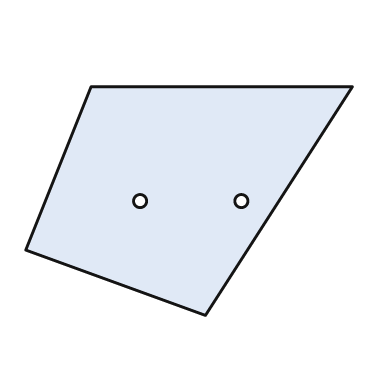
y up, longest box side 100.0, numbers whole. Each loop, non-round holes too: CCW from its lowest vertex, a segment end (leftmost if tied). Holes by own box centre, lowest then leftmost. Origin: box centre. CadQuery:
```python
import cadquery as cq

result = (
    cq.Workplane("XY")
    .moveTo(5.0, -35.0)
    .lineTo(50.0, 35.0)
    .lineTo(-30.0, 35.0)
    .lineTo(-50.0, -15.0)
    .close()
    .moveTo(-15.0, 0.0)
    .circle(2.0)
    .moveTo(16.0, 0.0)
    .circle(2.0)
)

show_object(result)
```